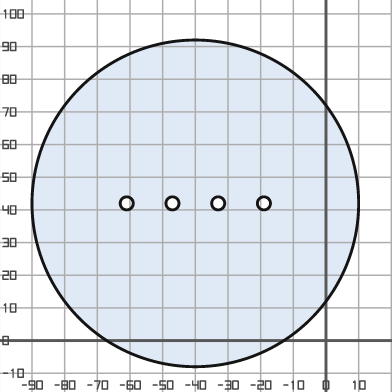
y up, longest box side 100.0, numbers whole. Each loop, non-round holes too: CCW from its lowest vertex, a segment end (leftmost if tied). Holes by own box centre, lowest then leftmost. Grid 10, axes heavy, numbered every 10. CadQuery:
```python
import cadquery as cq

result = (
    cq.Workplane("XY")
    .moveTo(-40.0, 42.0)
    .circle(50.0)
    .moveTo(-61.0, 42.0)
    .circle(2.0)
    .moveTo(-47.0, 42.0)
    .circle(2.0)
    .moveTo(-33.0, 42.0)
    .circle(2.0)
    .moveTo(-19.0, 42.0)
    .circle(2.0)
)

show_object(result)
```